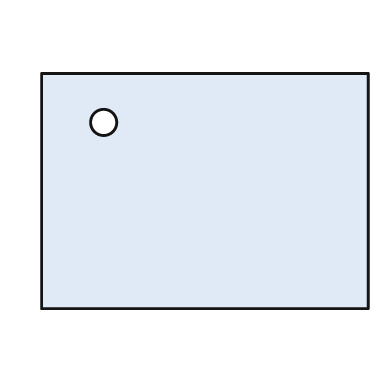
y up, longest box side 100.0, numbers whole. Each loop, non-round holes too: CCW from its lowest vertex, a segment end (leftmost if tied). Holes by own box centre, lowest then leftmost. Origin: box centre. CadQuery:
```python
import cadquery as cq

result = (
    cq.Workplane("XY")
    .moveTo(-50.0, -36.0)
    .lineTo(50.0, -36.0)
    .lineTo(50.0, 36.0)
    .lineTo(-50.0, 36.0)
    .close()
    .moveTo(-31.0, 21.0)
    .circle(4.0)
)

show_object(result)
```